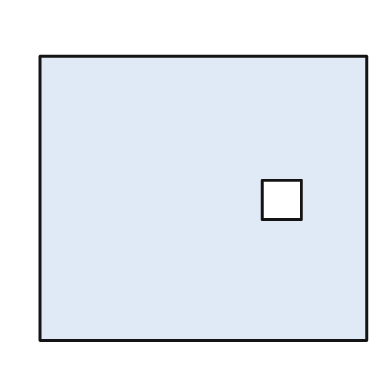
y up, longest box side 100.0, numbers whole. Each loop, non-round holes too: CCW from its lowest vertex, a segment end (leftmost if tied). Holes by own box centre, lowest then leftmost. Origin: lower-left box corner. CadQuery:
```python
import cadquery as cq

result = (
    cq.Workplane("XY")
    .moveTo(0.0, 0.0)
    .lineTo(100.0, 0.0)
    .lineTo(100.0, 87.0)
    .lineTo(0.0, 87.0)
    .close()
    .moveTo(68.0, 37.0)
    .lineTo(80.0, 37.0)
    .lineTo(80.0, 49.0)
    .lineTo(68.0, 49.0)
    .close()
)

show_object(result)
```